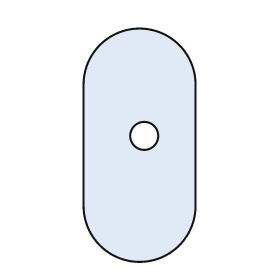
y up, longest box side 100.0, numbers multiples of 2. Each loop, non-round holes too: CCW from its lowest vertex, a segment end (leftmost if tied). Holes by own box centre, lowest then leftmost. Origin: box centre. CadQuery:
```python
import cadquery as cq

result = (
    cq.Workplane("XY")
    .moveTo(-24.0, -26.0)
    .threePointArc((0.0, -50.0), (24.0, -26.0))
    .lineTo(24.0, 26.0)
    .threePointArc((0.0, 50.0), (-24.0, 26.0))
    .close()
    .moveTo(2.0, 4.0)
    .circle(6.0)
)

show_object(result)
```